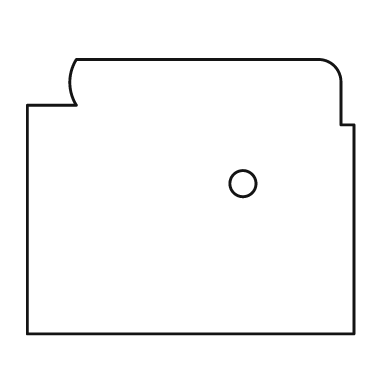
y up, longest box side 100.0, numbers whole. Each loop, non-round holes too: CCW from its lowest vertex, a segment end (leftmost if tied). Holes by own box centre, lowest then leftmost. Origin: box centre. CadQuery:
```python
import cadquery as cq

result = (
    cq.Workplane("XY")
    .moveTo(-50.0, -42.0)
    .lineTo(50.0, -42.0)
    .lineTo(50.0, 22.0)
    .lineTo(46.0, 22.0)
    .lineTo(46.0, 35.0)
    .threePointArc((44.0, 40.0), (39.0, 42.0))
    .lineTo(-35.0, 42.0)
    .threePointArc((-37.0, 35.0), (-35.0, 28.0))
    .lineTo(-50.0, 28.0)
    .close()
    .moveTo(16.0, 4.0)
    .circle(4.0)
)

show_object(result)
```